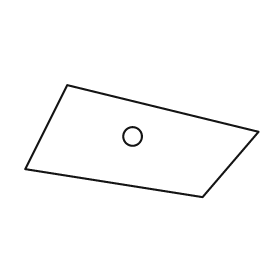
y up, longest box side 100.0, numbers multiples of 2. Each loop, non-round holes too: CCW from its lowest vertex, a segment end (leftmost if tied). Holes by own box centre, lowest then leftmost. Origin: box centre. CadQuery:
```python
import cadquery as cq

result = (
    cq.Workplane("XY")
    .moveTo(26.0, -24.0)
    .lineTo(50.0, 4.0)
    .lineTo(-32.0, 24.0)
    .lineTo(-50.0, -12.0)
    .close()
    .moveTo(-4.0, 2.0)
    .circle(4.0)
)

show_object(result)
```